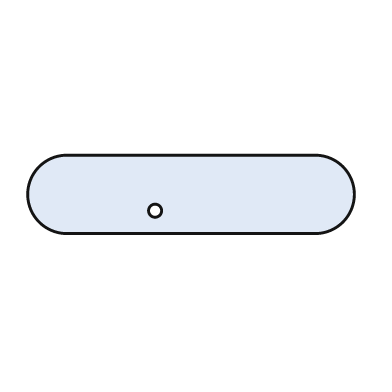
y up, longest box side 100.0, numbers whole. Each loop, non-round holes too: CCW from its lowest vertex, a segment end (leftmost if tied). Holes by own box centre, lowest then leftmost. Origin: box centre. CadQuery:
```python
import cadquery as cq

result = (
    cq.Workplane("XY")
    .moveTo(-38.0, -12.0)
    .lineTo(38.0, -12.0)
    .threePointArc((50.0, 0.0), (38.0, 12.0))
    .lineTo(-38.0, 12.0)
    .threePointArc((-50.0, 0.0), (-38.0, -12.0))
    .close()
    .moveTo(-11.0, -5.0)
    .circle(2.0)
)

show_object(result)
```